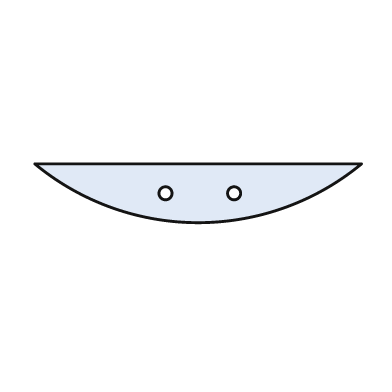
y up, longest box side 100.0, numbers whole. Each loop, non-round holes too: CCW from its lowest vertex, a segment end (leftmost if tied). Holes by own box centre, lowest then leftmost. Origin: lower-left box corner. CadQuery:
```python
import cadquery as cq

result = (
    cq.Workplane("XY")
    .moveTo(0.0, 18.0)
    .threePointArc((50.0, 0.0), (100.0, 18.0))
    .close()
    .moveTo(40.0, 9.0)
    .circle(2.0)
    .moveTo(61.0, 9.0)
    .circle(2.0)
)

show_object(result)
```